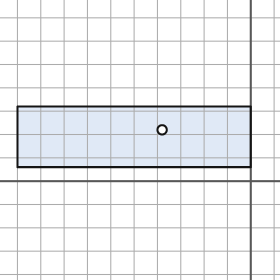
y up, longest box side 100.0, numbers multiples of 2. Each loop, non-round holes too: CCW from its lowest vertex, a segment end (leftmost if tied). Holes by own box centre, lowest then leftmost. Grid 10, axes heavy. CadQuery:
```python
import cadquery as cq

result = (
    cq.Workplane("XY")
    .moveTo(-100.0, 6.0)
    .lineTo(0.0, 6.0)
    .lineTo(0.0, 32.0)
    .lineTo(-100.0, 32.0)
    .close()
    .moveTo(-38.0, 22.0)
    .circle(2.0)
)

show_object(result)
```